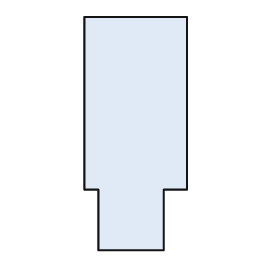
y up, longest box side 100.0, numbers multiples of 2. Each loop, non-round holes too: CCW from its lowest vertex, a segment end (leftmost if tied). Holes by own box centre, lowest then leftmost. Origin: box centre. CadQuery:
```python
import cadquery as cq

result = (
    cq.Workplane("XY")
    .moveTo(-16.0, -50.0)
    .lineTo(12.0, -50.0)
    .lineTo(12.0, -24.0)
    .lineTo(22.0, -24.0)
    .lineTo(22.0, 50.0)
    .lineTo(-22.0, 50.0)
    .lineTo(-22.0, -24.0)
    .lineTo(-16.0, -24.0)
    .close()
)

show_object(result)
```